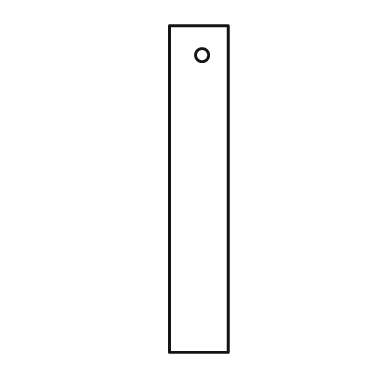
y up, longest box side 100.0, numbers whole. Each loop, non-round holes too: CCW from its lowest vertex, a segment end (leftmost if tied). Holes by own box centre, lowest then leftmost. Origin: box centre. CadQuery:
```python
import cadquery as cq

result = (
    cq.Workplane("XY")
    .moveTo(-9.0, -50.0)
    .lineTo(9.0, -50.0)
    .lineTo(9.0, 50.0)
    .lineTo(-9.0, 50.0)
    .close()
    .moveTo(1.0, 41.0)
    .circle(2.0)
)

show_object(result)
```